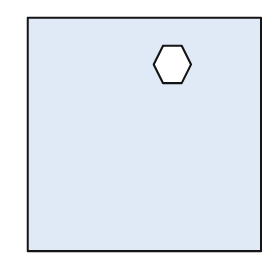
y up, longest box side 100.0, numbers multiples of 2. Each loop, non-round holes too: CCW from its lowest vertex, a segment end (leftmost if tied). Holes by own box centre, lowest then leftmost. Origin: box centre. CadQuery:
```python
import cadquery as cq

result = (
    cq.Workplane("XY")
    .moveTo(-50.0, -50.0)
    .lineTo(50.0, -50.0)
    .lineTo(50.0, 50.0)
    .lineTo(-50.0, 50.0)
    .close()
    .moveTo(8.0, 22.0)
    .lineTo(16.0, 22.0)
    .lineTo(20.0, 30.0)
    .lineTo(16.0, 38.0)
    .lineTo(8.0, 38.0)
    .lineTo(4.0, 30.0)
    .close()
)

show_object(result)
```